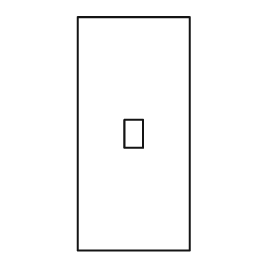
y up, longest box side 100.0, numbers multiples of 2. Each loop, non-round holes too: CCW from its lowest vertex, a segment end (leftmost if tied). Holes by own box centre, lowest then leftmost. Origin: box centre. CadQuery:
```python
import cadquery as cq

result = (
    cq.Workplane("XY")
    .moveTo(-24.0, -50.0)
    .lineTo(24.0, -50.0)
    .lineTo(24.0, 50.0)
    .lineTo(-24.0, 50.0)
    .close()
    .moveTo(-4.0, -6.0)
    .lineTo(4.0, -6.0)
    .lineTo(4.0, 6.0)
    .lineTo(-4.0, 6.0)
    .close()
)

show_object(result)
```